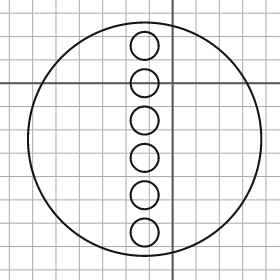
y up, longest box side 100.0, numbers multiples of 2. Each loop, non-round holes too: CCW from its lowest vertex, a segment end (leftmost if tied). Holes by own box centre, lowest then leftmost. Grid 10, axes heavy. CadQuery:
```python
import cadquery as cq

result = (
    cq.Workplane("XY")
    .moveTo(-12.0, -24.0)
    .circle(50.0)
    .moveTo(-12.0, -64.0)
    .circle(6.0)
    .moveTo(-12.0, -48.0)
    .circle(6.0)
    .moveTo(-12.0, -32.0)
    .circle(6.0)
    .moveTo(-12.0, -16.0)
    .circle(6.0)
    .moveTo(-12.0, 0.0)
    .circle(6.0)
    .moveTo(-12.0, 16.0)
    .circle(6.0)
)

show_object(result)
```